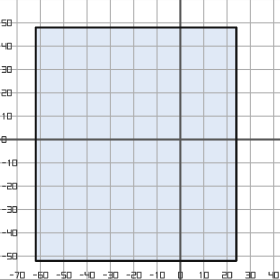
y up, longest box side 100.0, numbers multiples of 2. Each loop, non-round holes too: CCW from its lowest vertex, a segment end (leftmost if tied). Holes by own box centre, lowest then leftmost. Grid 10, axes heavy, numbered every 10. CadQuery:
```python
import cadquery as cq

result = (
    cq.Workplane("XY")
    .moveTo(-62.0, -52.0)
    .lineTo(24.0, -52.0)
    .lineTo(24.0, 48.0)
    .lineTo(-62.0, 48.0)
    .close()
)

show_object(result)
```